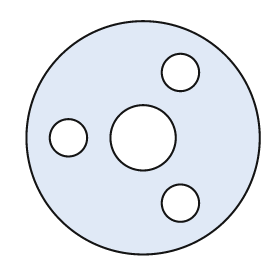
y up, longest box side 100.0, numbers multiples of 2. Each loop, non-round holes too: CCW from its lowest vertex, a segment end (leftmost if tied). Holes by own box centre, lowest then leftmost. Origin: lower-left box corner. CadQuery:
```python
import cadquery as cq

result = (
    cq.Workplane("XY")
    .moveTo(50.0, 50.0)
    .circle(50.0)
    .moveTo(66.0, 22.0)
    .circle(8.0)
    .moveTo(18.0, 50.0)
    .circle(8.0)
    .moveTo(50.0, 50.0)
    .circle(14.0)
    .moveTo(66.0, 78.0)
    .circle(8.0)
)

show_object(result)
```